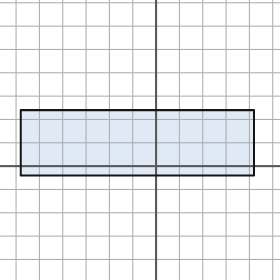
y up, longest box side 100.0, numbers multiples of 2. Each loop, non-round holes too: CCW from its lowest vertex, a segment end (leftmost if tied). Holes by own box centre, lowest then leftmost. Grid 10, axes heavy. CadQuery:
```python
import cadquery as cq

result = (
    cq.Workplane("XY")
    .moveTo(-58.0, -4.0)
    .lineTo(42.0, -4.0)
    .lineTo(42.0, 24.0)
    .lineTo(-58.0, 24.0)
    .close()
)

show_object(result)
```